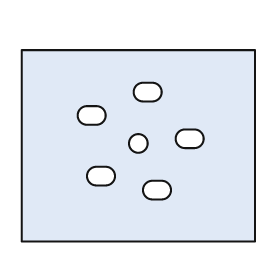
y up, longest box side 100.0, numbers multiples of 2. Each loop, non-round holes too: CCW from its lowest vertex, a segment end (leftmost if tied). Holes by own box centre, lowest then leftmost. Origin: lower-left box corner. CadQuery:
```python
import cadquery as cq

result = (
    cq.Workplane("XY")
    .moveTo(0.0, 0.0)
    .lineTo(100.0, 0.0)
    .lineTo(100.0, 82.0)
    .lineTo(0.0, 82.0)
    .close()
    .moveTo(56.0, 18.0)
    .lineTo(60.0, 18.0)
    .threePointArc((64.0, 22.0), (60.0, 26.0))
    .lineTo(56.0, 26.0)
    .threePointArc((52.0, 22.0), (56.0, 18.0))
    .close()
    .moveTo(32.0, 24.0)
    .lineTo(36.0, 24.0)
    .threePointArc((40.0, 28.0), (36.0, 32.0))
    .lineTo(32.0, 32.0)
    .threePointArc((28.0, 28.0), (32.0, 24.0))
    .close()
    .moveTo(50.0, 42.0)
    .circle(4.0)
    .moveTo(70.0, 40.0)
    .lineTo(74.0, 40.0)
    .threePointArc((78.0, 44.0), (74.0, 48.0))
    .lineTo(70.0, 48.0)
    .threePointArc((66.0, 44.0), (70.0, 40.0))
    .close()
    .moveTo(28.0, 50.0)
    .lineTo(32.0, 50.0)
    .threePointArc((36.0, 54.0), (32.0, 58.0))
    .lineTo(28.0, 58.0)
    .threePointArc((24.0, 54.0), (28.0, 50.0))
    .close()
    .moveTo(52.0, 60.0)
    .lineTo(56.0, 60.0)
    .threePointArc((60.0, 64.0), (56.0, 68.0))
    .lineTo(52.0, 68.0)
    .threePointArc((48.0, 64.0), (52.0, 60.0))
    .close()
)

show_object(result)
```